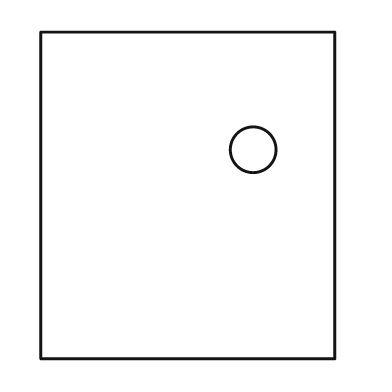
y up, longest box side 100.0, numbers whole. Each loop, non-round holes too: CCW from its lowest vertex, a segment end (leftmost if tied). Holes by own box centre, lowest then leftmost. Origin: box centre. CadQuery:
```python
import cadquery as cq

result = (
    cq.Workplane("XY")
    .moveTo(-45.0, -50.0)
    .lineTo(45.0, -50.0)
    .lineTo(45.0, 50.0)
    .lineTo(-45.0, 50.0)
    .close()
    .moveTo(20.0, 14.0)
    .circle(7.0)
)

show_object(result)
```